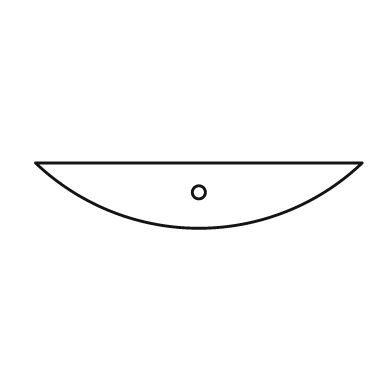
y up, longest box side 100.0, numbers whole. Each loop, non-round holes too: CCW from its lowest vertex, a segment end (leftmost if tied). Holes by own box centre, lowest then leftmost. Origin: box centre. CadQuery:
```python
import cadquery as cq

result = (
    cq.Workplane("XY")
    .moveTo(-50.0, 10.0)
    .threePointArc((0.0, -10.0), (50.0, 10.0))
    .close()
    .moveTo(0.0, 1.0)
    .circle(2.0)
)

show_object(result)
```